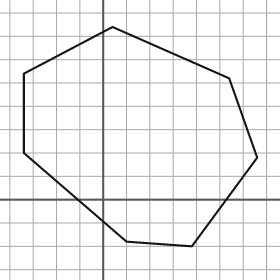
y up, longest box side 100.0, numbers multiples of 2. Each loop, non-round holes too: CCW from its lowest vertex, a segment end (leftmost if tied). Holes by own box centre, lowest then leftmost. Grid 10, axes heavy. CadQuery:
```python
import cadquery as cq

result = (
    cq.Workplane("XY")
    .moveTo(38.0, -20.0)
    .lineTo(66.0, 18.0)
    .lineTo(54.0, 52.0)
    .lineTo(4.0, 74.0)
    .lineTo(-34.0, 54.0)
    .lineTo(-34.0, 20.0)
    .lineTo(10.0, -18.0)
    .close()
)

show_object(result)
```